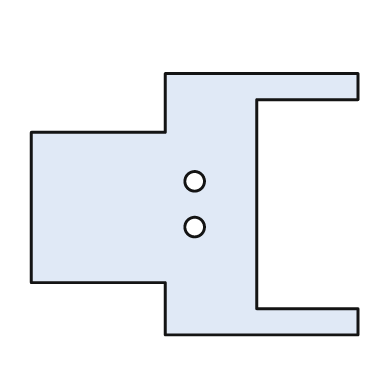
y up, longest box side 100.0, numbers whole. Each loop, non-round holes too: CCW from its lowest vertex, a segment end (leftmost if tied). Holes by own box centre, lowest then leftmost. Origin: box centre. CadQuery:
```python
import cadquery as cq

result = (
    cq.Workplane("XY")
    .moveTo(-9.0, -40.0)
    .lineTo(50.0, -40.0)
    .lineTo(50.0, -32.0)
    .lineTo(19.0, -32.0)
    .lineTo(19.0, 32.0)
    .lineTo(50.0, 32.0)
    .lineTo(50.0, 40.0)
    .lineTo(-9.0, 40.0)
    .lineTo(-9.0, 22.0)
    .lineTo(-50.0, 22.0)
    .lineTo(-50.0, -24.0)
    .lineTo(-9.0, -24.0)
    .close()
    .moveTo(0.0, -7.0)
    .circle(3.0)
    .moveTo(0.0, 7.0)
    .circle(3.0)
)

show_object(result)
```